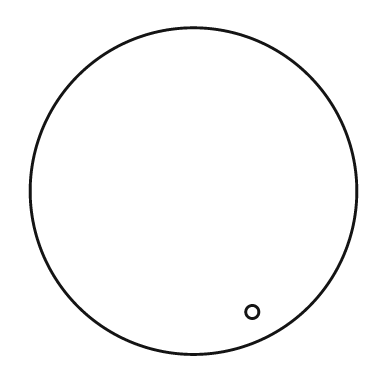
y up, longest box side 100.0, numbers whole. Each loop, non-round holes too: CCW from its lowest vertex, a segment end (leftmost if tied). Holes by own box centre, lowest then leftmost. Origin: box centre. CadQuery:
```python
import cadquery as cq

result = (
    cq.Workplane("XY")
    .moveTo(0.0, 0.0)
    .circle(50.0)
    .moveTo(18.0, -37.0)
    .circle(2.0)
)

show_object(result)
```